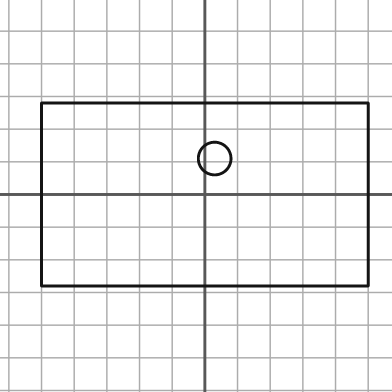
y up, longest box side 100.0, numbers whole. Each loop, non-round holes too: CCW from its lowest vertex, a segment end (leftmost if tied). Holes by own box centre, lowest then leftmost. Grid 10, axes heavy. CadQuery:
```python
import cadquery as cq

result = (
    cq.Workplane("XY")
    .moveTo(-50.0, -28.0)
    .lineTo(50.0, -28.0)
    .lineTo(50.0, 28.0)
    .lineTo(-50.0, 28.0)
    .close()
    .moveTo(3.0, 11.0)
    .circle(5.0)
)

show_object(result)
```